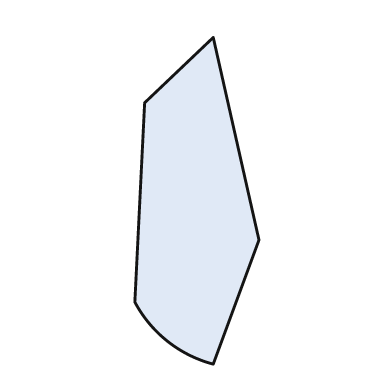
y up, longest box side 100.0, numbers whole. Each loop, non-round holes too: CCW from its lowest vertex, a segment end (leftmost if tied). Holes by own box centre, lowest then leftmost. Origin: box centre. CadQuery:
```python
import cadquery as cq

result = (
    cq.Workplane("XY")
    .moveTo(5.0, -50.0)
    .lineTo(19.0, -12.0)
    .lineTo(5.0, 50.0)
    .lineTo(-16.0, 30.0)
    .lineTo(-19.0, -31.0)
    .threePointArc((-9.0, -43.0), (5.0, -50.0))
    .close()
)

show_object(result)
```